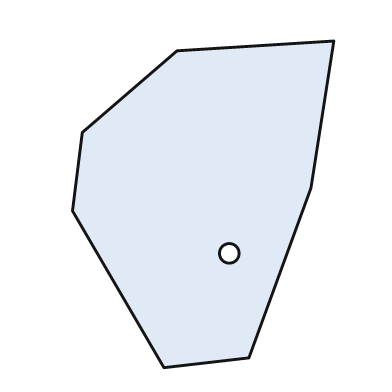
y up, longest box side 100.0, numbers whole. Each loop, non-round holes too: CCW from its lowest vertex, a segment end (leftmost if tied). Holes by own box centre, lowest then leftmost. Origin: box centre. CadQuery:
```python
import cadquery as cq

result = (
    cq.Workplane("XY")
    .moveTo(-12.0, -50.0)
    .lineTo(14.0, -47.0)
    .lineTo(33.0, 5.0)
    .lineTo(40.0, 50.0)
    .lineTo(-8.0, 47.0)
    .lineTo(-37.0, 22.0)
    .lineTo(-40.0, -2.0)
    .close()
    .moveTo(8.0, -15.0)
    .circle(3.0)
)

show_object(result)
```